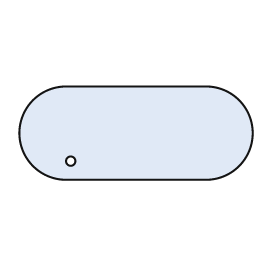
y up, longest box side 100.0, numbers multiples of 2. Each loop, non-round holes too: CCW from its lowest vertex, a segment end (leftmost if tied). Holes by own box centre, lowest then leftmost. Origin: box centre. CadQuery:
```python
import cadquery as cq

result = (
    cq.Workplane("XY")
    .moveTo(-30.0, -20.0)
    .lineTo(30.0, -20.0)
    .threePointArc((50.0, 0.0), (30.0, 20.0))
    .lineTo(-30.0, 20.0)
    .threePointArc((-50.0, 0.0), (-30.0, -20.0))
    .close()
    .moveTo(-28.0, -12.0)
    .circle(2.0)
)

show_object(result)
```